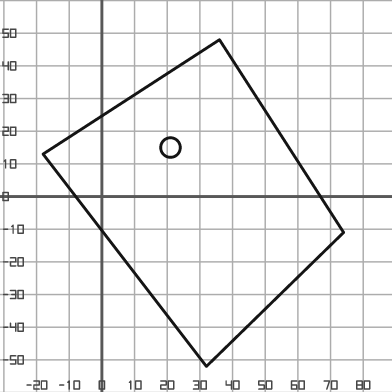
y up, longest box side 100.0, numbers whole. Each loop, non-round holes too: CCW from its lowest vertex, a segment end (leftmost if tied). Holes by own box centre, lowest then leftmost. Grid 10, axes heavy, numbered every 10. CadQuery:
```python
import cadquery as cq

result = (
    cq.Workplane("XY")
    .moveTo(32.0, -52.0)
    .lineTo(74.0, -11.0)
    .lineTo(36.0, 48.0)
    .lineTo(-18.0, 13.0)
    .close()
    .moveTo(21.0, 15.0)
    .circle(3.0)
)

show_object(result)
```